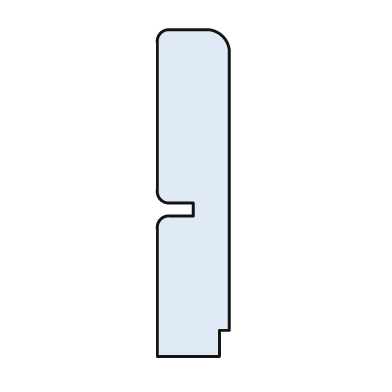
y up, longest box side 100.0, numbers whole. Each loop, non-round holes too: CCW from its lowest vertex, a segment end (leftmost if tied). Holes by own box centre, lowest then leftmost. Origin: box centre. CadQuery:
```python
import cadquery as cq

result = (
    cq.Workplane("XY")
    .moveTo(-11.0, -50.0)
    .lineTo(8.0, -50.0)
    .lineTo(8.0, -42.0)
    .lineTo(11.0, -42.0)
    .lineTo(11.0, 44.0)
    .threePointArc((9.0, 48.0), (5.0, 50.0))
    .lineTo(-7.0, 50.0)
    .threePointArc((-10.0, 49.0), (-11.0, 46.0))
    .lineTo(-11.0, 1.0)
    .threePointArc((-10.0, -2.0), (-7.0, -3.0))
    .lineTo(0.0, -3.0)
    .lineTo(0.0, -7.0)
    .lineTo(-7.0, -7.0)
    .threePointArc((-10.0, -8.0), (-11.0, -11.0))
    .close()
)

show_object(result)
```